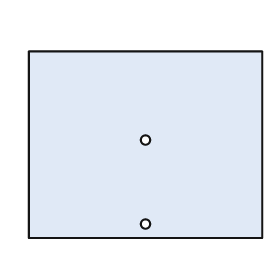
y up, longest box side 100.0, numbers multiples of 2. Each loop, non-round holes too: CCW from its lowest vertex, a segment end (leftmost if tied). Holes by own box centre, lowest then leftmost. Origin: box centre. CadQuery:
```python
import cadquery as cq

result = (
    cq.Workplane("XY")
    .moveTo(-50.0, -40.0)
    .lineTo(50.0, -40.0)
    .lineTo(50.0, 40.0)
    .lineTo(-50.0, 40.0)
    .close()
    .moveTo(0.0, -34.0)
    .circle(2.0)
    .moveTo(0.0, 2.0)
    .circle(2.0)
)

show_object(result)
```